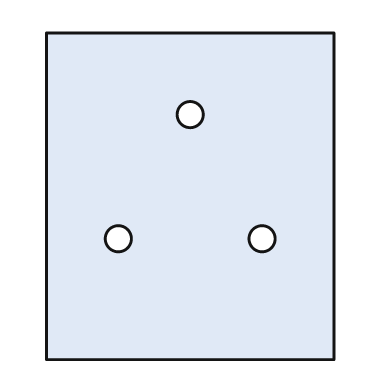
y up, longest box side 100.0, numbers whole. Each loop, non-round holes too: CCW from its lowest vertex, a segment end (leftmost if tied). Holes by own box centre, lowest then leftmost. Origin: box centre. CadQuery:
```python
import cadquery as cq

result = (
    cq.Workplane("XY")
    .moveTo(-44.0, -50.0)
    .lineTo(44.0, -50.0)
    .lineTo(44.0, 50.0)
    .lineTo(-44.0, 50.0)
    .close()
    .moveTo(-22.0, -13.0)
    .circle(4.0)
    .moveTo(22.0, -13.0)
    .circle(4.0)
    .moveTo(0.0, 25.0)
    .circle(4.0)
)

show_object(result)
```